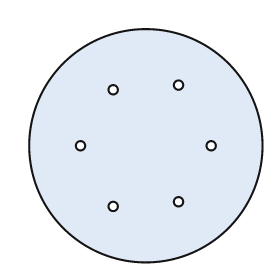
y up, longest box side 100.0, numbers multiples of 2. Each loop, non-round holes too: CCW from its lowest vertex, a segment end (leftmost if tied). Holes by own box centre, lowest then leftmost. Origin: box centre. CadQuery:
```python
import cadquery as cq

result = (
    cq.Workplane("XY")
    .moveTo(0.0, 0.0)
    .circle(50.0)
    .moveTo(-14.0, -26.0)
    .circle(2.0)
    .moveTo(14.0, -24.0)
    .circle(2.0)
    .moveTo(-28.0, 0.0)
    .circle(2.0)
    .moveTo(28.0, 0.0)
    .circle(2.0)
    .moveTo(-14.0, 24.0)
    .circle(2.0)
    .moveTo(14.0, 26.0)
    .circle(2.0)
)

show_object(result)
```